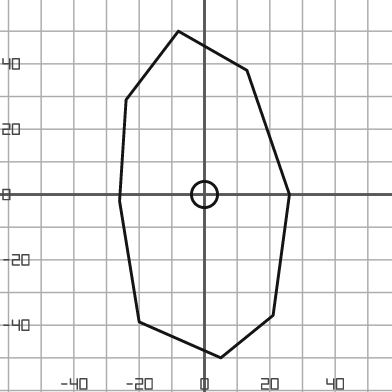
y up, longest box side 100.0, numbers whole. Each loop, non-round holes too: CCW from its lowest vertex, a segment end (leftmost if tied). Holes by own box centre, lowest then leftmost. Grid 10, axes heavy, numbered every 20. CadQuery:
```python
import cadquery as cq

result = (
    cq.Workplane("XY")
    .moveTo(5.0, -50.0)
    .lineTo(21.0, -37.0)
    .lineTo(26.0, 0.0)
    .lineTo(13.0, 38.0)
    .lineTo(-8.0, 50.0)
    .lineTo(-24.0, 29.0)
    .lineTo(-26.0, -2.0)
    .lineTo(-20.0, -39.0)
    .close()
    .moveTo(0.0, 0.0)
    .circle(4.0)
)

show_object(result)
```